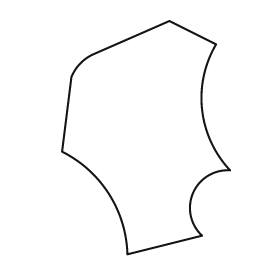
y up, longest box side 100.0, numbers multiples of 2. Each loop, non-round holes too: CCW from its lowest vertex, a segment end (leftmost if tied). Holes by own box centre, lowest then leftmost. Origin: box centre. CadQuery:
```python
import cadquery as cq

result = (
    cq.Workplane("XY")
    .moveTo(-8.0, -50.0)
    .lineTo(24.0, -42.0)
    .threePointArc((20.0, -24.0), (36.0, -14.0))
    .threePointArc((24.0, 12.0), (30.0, 40.0))
    .lineTo(10.0, 50.0)
    .lineTo(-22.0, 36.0)
    .threePointArc((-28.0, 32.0), (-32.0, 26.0))
    .lineTo(-36.0, -6.0)
    .threePointArc((-16.0, -24.0), (-8.0, -50.0))
    .close()
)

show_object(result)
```